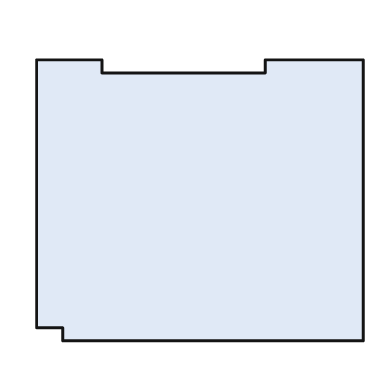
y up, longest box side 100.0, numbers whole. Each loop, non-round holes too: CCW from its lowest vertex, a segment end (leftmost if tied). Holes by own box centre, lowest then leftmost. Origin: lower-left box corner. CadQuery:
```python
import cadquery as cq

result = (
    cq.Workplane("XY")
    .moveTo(8.0, 0.0)
    .lineTo(100.0, 0.0)
    .lineTo(100.0, 86.0)
    .lineTo(70.0, 86.0)
    .lineTo(70.0, 82.0)
    .lineTo(20.0, 82.0)
    .lineTo(20.0, 86.0)
    .lineTo(0.0, 86.0)
    .lineTo(0.0, 4.0)
    .lineTo(8.0, 4.0)
    .close()
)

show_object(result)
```